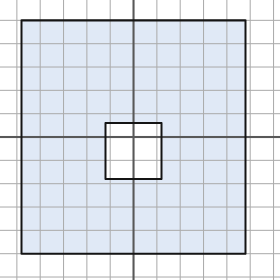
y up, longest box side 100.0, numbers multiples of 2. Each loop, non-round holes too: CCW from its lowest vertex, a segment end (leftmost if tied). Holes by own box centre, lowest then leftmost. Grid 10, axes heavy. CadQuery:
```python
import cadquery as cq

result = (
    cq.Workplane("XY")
    .moveTo(-48.0, -50.0)
    .lineTo(48.0, -50.0)
    .lineTo(48.0, 50.0)
    .lineTo(-48.0, 50.0)
    .close()
    .moveTo(-12.0, -18.0)
    .lineTo(12.0, -18.0)
    .lineTo(12.0, 6.0)
    .lineTo(-12.0, 6.0)
    .close()
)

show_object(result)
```